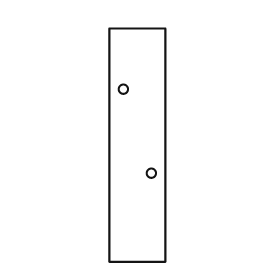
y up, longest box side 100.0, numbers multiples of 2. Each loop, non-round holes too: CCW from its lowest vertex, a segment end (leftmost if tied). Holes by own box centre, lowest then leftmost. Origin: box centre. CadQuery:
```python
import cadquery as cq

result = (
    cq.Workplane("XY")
    .moveTo(-12.0, -50.0)
    .lineTo(12.0, -50.0)
    .lineTo(12.0, 50.0)
    .lineTo(-12.0, 50.0)
    .close()
    .moveTo(6.0, -12.0)
    .circle(2.0)
    .moveTo(-6.0, 24.0)
    .circle(2.0)
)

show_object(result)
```